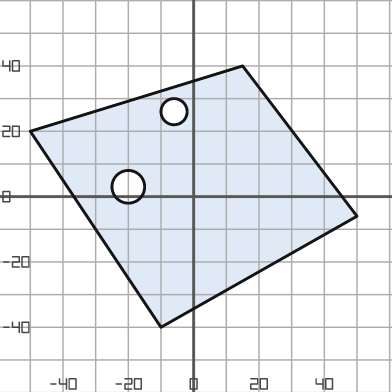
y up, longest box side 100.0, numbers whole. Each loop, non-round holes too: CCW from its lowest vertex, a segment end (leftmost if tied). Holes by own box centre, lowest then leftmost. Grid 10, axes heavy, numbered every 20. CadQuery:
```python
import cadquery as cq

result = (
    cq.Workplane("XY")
    .moveTo(-10.0, -40.0)
    .lineTo(50.0, -6.0)
    .lineTo(15.0, 40.0)
    .lineTo(-50.0, 20.0)
    .close()
    .moveTo(-20.0, 3.0)
    .circle(5.0)
    .moveTo(-6.0, 26.0)
    .circle(4.0)
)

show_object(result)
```